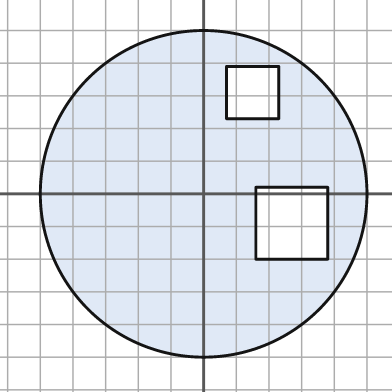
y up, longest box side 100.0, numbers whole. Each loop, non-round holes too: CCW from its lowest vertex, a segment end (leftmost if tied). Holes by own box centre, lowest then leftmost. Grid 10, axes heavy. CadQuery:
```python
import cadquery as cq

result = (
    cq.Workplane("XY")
    .moveTo(0.0, 0.0)
    .circle(50.0)
    .moveTo(16.0, -20.0)
    .lineTo(38.0, -20.0)
    .lineTo(38.0, 2.0)
    .lineTo(16.0, 2.0)
    .close()
    .moveTo(7.0, 23.0)
    .lineTo(23.0, 23.0)
    .lineTo(23.0, 39.0)
    .lineTo(7.0, 39.0)
    .close()
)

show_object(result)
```